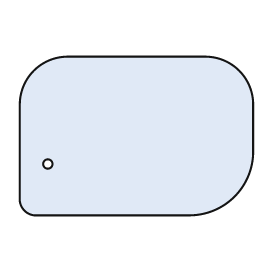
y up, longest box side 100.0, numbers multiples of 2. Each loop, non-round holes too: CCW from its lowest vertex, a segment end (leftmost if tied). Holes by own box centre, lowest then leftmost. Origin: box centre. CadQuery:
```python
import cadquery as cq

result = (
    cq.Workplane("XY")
    .moveTo(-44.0, -34.0)
    .lineTo(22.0, -34.0)
    .threePointArc((42.0, -26.0), (50.0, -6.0))
    .lineTo(50.0, 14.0)
    .threePointArc((44.0, 28.0), (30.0, 34.0))
    .lineTo(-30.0, 34.0)
    .threePointArc((-44.0, 28.0), (-50.0, 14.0))
    .lineTo(-50.0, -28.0)
    .threePointArc((-48.0, -32.0), (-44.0, -34.0))
    .close()
    .moveTo(-38.0, -12.0)
    .circle(2.0)
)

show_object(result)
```